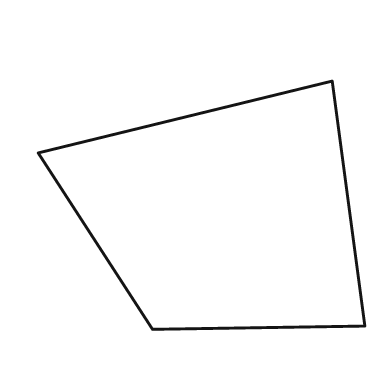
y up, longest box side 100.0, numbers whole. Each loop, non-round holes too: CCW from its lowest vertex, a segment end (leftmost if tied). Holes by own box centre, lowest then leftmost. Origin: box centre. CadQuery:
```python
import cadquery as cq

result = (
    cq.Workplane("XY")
    .moveTo(-15.0, -38.0)
    .lineTo(50.0, -37.0)
    .lineTo(40.0, 38.0)
    .lineTo(-50.0, 16.0)
    .close()
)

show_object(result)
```